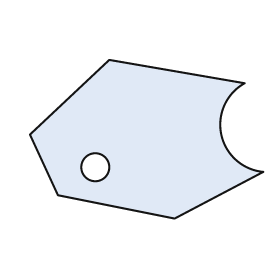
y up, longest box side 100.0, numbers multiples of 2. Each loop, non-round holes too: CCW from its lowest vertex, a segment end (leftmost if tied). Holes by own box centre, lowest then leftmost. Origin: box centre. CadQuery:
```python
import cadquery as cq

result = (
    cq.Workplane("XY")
    .moveTo(12.0, -34.0)
    .lineTo(50.0, -14.0)
    .threePointArc((32.0, 2.0), (42.0, 24.0))
    .lineTo(-16.0, 34.0)
    .lineTo(-50.0, 2.0)
    .lineTo(-38.0, -24.0)
    .close()
    .moveTo(-22.0, -12.0)
    .circle(6.0)
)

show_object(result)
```